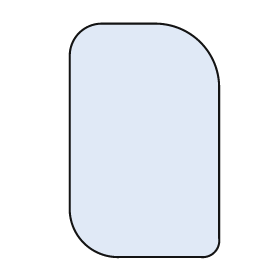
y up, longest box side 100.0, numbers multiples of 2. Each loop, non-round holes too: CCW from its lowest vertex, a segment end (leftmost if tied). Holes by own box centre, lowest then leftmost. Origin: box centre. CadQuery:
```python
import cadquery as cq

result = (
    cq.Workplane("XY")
    .moveTo(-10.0, -50.0)
    .lineTo(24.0, -50.0)
    .threePointArc((30.0, -48.0), (32.0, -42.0))
    .lineTo(32.0, 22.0)
    .threePointArc((24.0, 42.0), (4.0, 50.0))
    .lineTo(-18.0, 50.0)
    .threePointArc((-28.0, 46.0), (-32.0, 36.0))
    .lineTo(-32.0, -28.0)
    .threePointArc((-26.0, -44.0), (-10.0, -50.0))
    .close()
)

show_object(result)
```